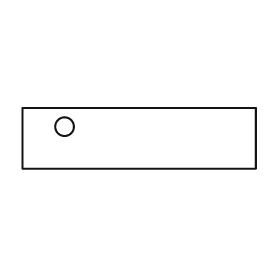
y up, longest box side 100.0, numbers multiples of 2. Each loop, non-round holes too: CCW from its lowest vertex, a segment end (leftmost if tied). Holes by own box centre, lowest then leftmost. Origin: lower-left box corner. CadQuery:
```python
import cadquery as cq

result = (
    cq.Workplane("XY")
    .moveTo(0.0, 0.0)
    .lineTo(100.0, 0.0)
    .lineTo(100.0, 26.0)
    .lineTo(0.0, 26.0)
    .close()
    .moveTo(18.0, 18.0)
    .circle(4.0)
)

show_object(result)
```